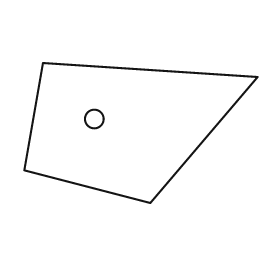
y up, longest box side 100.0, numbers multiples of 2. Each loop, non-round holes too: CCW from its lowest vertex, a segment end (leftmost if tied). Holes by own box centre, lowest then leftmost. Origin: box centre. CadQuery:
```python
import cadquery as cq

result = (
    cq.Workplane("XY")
    .moveTo(4.0, -30.0)
    .lineTo(50.0, 24.0)
    .lineTo(-42.0, 30.0)
    .lineTo(-50.0, -16.0)
    .close()
    .moveTo(-20.0, 6.0)
    .circle(4.0)
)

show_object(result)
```